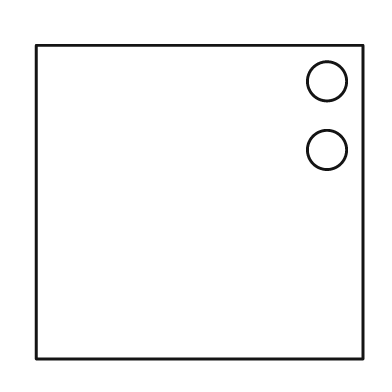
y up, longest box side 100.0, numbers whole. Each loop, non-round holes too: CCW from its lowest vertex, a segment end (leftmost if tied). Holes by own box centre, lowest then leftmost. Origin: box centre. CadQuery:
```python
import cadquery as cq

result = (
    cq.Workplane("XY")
    .moveTo(-50.0, -48.0)
    .lineTo(50.0, -48.0)
    .lineTo(50.0, 48.0)
    .lineTo(-50.0, 48.0)
    .close()
    .moveTo(39.0, 16.0)
    .circle(6.0)
    .moveTo(39.0, 37.0)
    .circle(6.0)
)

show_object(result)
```